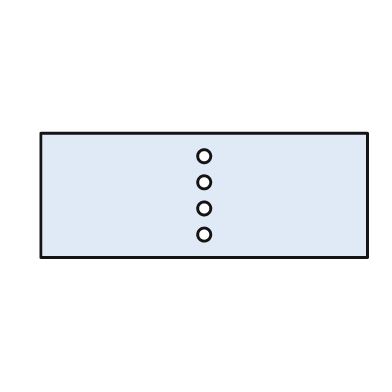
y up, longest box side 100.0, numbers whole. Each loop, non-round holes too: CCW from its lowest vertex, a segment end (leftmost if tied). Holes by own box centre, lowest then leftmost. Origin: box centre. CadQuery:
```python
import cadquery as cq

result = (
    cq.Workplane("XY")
    .moveTo(-50.0, -19.0)
    .lineTo(50.0, -19.0)
    .lineTo(50.0, 19.0)
    .lineTo(-50.0, 19.0)
    .close()
    .moveTo(0.0, -12.0)
    .circle(2.0)
    .moveTo(0.0, -4.0)
    .circle(2.0)
    .moveTo(0.0, 4.0)
    .circle(2.0)
    .moveTo(0.0, 12.0)
    .circle(2.0)
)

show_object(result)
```